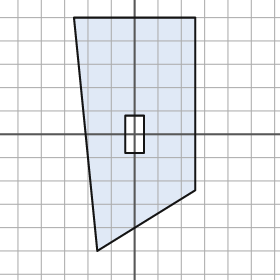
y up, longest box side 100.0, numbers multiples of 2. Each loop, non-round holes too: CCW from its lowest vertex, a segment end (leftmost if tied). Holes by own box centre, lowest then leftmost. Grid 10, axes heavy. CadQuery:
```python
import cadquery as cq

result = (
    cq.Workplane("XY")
    .moveTo(-16.0, -50.0)
    .lineTo(26.0, -24.0)
    .lineTo(26.0, 50.0)
    .lineTo(-26.0, 50.0)
    .close()
    .moveTo(-4.0, -8.0)
    .lineTo(4.0, -8.0)
    .lineTo(4.0, 8.0)
    .lineTo(-4.0, 8.0)
    .close()
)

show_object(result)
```